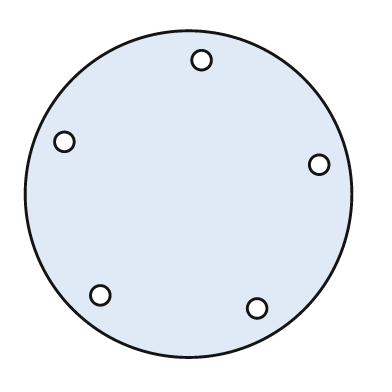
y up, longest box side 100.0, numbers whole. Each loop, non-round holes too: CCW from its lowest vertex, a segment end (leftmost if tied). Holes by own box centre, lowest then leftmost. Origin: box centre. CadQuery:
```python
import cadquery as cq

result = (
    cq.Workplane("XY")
    .moveTo(0.0, 0.0)
    .circle(50.0)
    .moveTo(21.0, -35.0)
    .circle(3.0)
    .moveTo(-27.0, -31.0)
    .circle(3.0)
    .moveTo(40.0, 9.0)
    .circle(3.0)
    .moveTo(-38.0, 16.0)
    .circle(3.0)
    .moveTo(4.0, 41.0)
    .circle(3.0)
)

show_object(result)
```